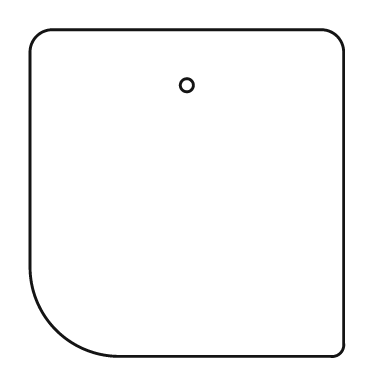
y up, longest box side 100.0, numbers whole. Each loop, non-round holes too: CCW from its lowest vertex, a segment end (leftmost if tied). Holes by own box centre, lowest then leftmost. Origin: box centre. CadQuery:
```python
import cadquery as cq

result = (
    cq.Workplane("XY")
    .moveTo(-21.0, -50.0)
    .lineTo(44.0, -50.0)
    .threePointArc((47.0, -49.0), (48.0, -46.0))
    .lineTo(48.0, 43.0)
    .threePointArc((46.0, 48.0), (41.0, 50.0))
    .lineTo(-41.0, 50.0)
    .threePointArc((-46.0, 48.0), (-48.0, 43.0))
    .lineTo(-48.0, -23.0)
    .threePointArc((-40.0, -42.0), (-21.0, -50.0))
    .close()
    .moveTo(0.0, 33.0)
    .circle(2.0)
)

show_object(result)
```